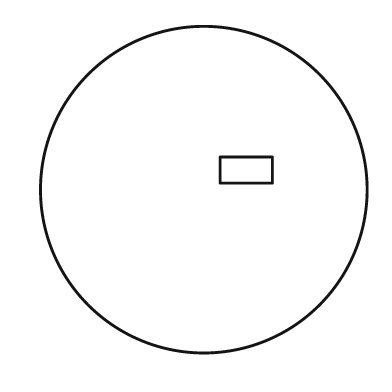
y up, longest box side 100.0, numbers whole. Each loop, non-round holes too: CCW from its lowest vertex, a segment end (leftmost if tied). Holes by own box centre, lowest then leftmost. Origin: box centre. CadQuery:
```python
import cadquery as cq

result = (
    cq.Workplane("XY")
    .moveTo(0.0, 0.0)
    .circle(50.0)
    .moveTo(5.0, 2.0)
    .lineTo(21.0, 2.0)
    .lineTo(21.0, 10.0)
    .lineTo(5.0, 10.0)
    .close()
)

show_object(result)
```